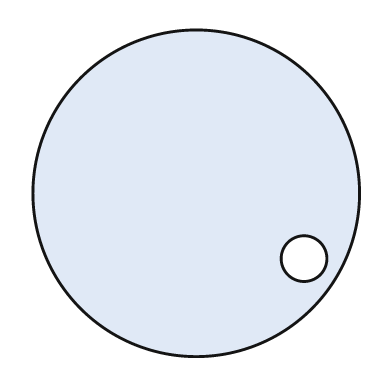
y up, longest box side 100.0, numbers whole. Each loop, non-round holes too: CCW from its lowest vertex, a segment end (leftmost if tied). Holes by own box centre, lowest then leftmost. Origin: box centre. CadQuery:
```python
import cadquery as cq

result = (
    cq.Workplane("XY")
    .moveTo(0.0, 0.0)
    .circle(50.0)
    .moveTo(33.0, -20.0)
    .circle(7.0)
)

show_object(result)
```